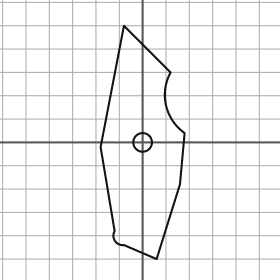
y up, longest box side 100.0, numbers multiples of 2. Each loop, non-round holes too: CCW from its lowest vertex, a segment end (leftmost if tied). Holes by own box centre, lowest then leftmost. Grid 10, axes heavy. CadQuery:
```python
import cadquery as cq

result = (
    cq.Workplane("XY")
    .moveTo(6.0, -50.0)
    .lineTo(16.0, -18.0)
    .lineTo(18.0, 4.0)
    .threePointArc((10.0, 16.0), (12.0, 30.0))
    .lineTo(-8.0, 50.0)
    .lineTo(-18.0, -2.0)
    .lineTo(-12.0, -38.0)
    .threePointArc((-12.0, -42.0), (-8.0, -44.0))
    .close()
    .moveTo(0.0, 0.0)
    .circle(4.0)
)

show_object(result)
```